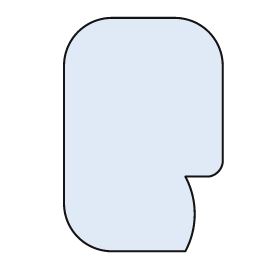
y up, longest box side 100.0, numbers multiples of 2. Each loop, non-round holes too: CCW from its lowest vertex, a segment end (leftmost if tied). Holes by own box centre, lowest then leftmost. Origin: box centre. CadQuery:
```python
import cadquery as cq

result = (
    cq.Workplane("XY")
    .moveTo(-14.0, -50.0)
    .lineTo(18.0, -50.0)
    .threePointArc((22.0, -34.0), (18.0, -18.0))
    .lineTo(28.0, -18.0)
    .threePointArc((32.0, -16.0), (34.0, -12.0))
    .lineTo(34.0, 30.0)
    .threePointArc((28.0, 44.0), (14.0, 50.0))
    .lineTo(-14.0, 50.0)
    .threePointArc((-28.0, 44.0), (-34.0, 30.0))
    .lineTo(-34.0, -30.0)
    .threePointArc((-28.0, -44.0), (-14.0, -50.0))
    .close()
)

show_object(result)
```